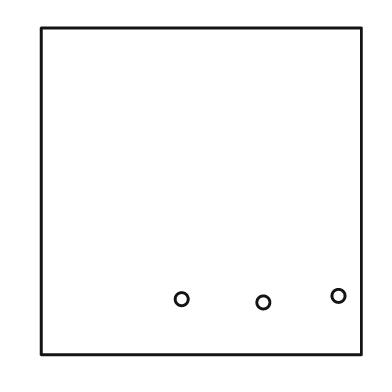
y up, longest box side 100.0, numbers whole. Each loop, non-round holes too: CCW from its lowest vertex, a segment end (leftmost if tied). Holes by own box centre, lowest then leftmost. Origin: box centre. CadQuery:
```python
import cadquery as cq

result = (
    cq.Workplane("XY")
    .moveTo(-49.0, -50.0)
    .lineTo(49.0, -50.0)
    .lineTo(49.0, 50.0)
    .lineTo(-49.0, 50.0)
    .close()
    .moveTo(19.0, -34.0)
    .circle(2.0)
    .moveTo(-6.0, -33.0)
    .circle(2.0)
    .moveTo(42.0, -32.0)
    .circle(2.0)
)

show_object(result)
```